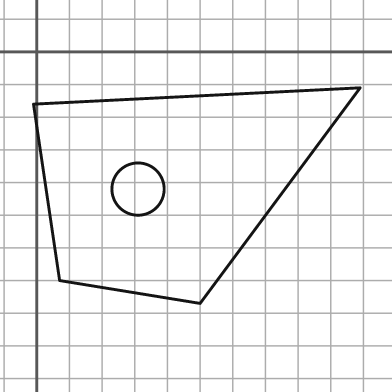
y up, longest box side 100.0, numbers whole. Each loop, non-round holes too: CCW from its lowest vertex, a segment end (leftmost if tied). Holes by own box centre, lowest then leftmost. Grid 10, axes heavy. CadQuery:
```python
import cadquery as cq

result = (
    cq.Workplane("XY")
    .moveTo(50.0, -77.0)
    .lineTo(99.0, -11.0)
    .lineTo(-1.0, -16.0)
    .lineTo(7.0, -70.0)
    .close()
    .moveTo(31.0, -42.0)
    .circle(8.0)
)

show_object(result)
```